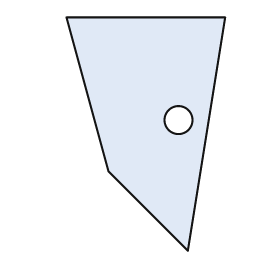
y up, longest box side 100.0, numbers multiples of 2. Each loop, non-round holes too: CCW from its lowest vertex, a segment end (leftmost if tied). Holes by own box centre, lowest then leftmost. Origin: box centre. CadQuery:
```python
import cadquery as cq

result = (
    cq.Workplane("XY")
    .moveTo(18.0, -50.0)
    .lineTo(34.0, 50.0)
    .lineTo(-34.0, 50.0)
    .lineTo(-16.0, -16.0)
    .close()
    .moveTo(14.0, 6.0)
    .circle(6.0)
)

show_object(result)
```